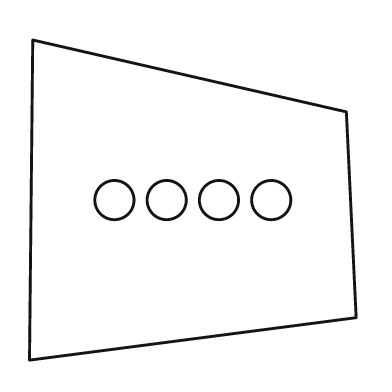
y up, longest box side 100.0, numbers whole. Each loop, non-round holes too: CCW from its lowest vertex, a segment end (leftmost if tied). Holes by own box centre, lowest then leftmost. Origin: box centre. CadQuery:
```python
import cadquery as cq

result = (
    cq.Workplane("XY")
    .moveTo(-50.0, -49.0)
    .lineTo(50.0, -36.0)
    .lineTo(47.0, 27.0)
    .lineTo(-49.0, 49.0)
    .close()
    .moveTo(-24.0, 0.0)
    .circle(6.0)
    .moveTo(-8.0, 0.0)
    .circle(6.0)
    .moveTo(8.0, 0.0)
    .circle(6.0)
    .moveTo(24.0, 0.0)
    .circle(6.0)
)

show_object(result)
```